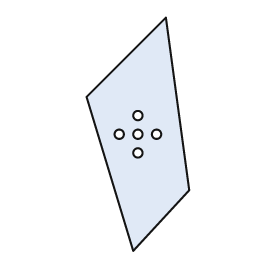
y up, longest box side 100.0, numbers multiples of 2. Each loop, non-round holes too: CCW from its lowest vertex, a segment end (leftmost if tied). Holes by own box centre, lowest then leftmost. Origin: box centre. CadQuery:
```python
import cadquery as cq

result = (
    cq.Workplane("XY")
    .moveTo(-2.0, -50.0)
    .lineTo(22.0, -24.0)
    .lineTo(12.0, 50.0)
    .lineTo(-22.0, 16.0)
    .close()
    .moveTo(0.0, -8.0)
    .circle(2.0)
    .moveTo(-8.0, 0.0)
    .circle(2.0)
    .moveTo(0.0, 0.0)
    .circle(2.0)
    .moveTo(8.0, 0.0)
    .circle(2.0)
    .moveTo(0.0, 8.0)
    .circle(2.0)
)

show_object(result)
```